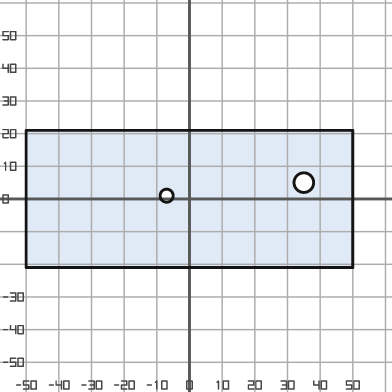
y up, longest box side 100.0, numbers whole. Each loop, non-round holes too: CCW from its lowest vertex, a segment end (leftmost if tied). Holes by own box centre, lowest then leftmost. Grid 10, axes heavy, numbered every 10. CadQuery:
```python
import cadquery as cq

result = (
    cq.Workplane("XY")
    .moveTo(-50.0, -21.0)
    .lineTo(50.0, -21.0)
    .lineTo(50.0, 21.0)
    .lineTo(-50.0, 21.0)
    .close()
    .moveTo(-7.0, 1.0)
    .circle(2.0)
    .moveTo(35.0, 5.0)
    .circle(3.0)
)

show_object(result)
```